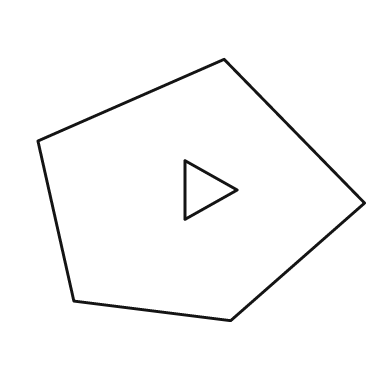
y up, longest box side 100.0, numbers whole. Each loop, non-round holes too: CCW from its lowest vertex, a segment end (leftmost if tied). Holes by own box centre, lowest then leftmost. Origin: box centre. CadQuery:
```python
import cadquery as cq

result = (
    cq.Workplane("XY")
    .moveTo(9.0, -40.0)
    .lineTo(50.0, -4.0)
    .lineTo(7.0, 40.0)
    .lineTo(-50.0, 15.0)
    .lineTo(-39.0, -34.0)
    .close()
    .moveTo(-5.0, -9.0)
    .lineTo(11.0, 0.0)
    .lineTo(-5.0, 9.0)
    .close()
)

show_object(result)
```